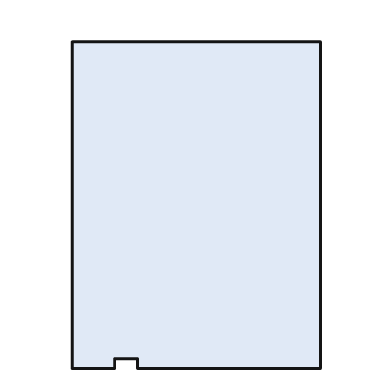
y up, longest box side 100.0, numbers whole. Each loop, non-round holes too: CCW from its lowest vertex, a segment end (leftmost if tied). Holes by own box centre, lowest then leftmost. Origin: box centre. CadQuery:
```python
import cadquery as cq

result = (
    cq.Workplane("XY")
    .moveTo(-38.0, -50.0)
    .lineTo(-25.0, -50.0)
    .lineTo(-25.0, -47.0)
    .lineTo(-18.0, -47.0)
    .lineTo(-18.0, -50.0)
    .lineTo(38.0, -50.0)
    .lineTo(38.0, 50.0)
    .lineTo(-38.0, 50.0)
    .close()
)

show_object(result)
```